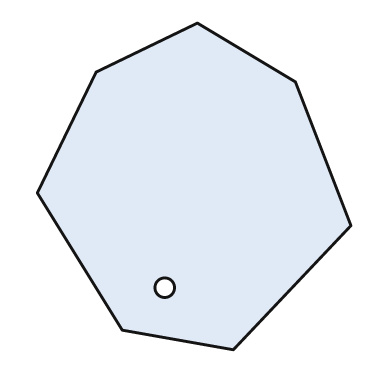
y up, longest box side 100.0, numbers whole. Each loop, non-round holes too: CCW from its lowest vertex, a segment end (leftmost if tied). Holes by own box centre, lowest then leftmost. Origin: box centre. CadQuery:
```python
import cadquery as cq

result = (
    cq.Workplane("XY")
    .moveTo(12.0, -50.0)
    .lineTo(48.0, -12.0)
    .lineTo(31.0, 32.0)
    .lineTo(1.0, 50.0)
    .lineTo(-30.0, 35.0)
    .lineTo(-48.0, -2.0)
    .lineTo(-22.0, -44.0)
    .close()
    .moveTo(-9.0, -31.0)
    .circle(3.0)
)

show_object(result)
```